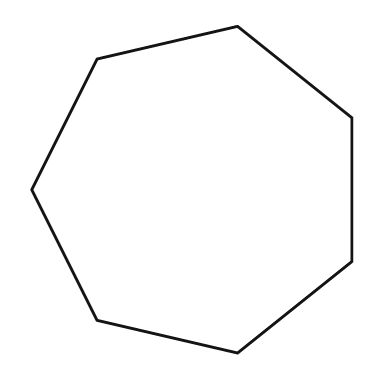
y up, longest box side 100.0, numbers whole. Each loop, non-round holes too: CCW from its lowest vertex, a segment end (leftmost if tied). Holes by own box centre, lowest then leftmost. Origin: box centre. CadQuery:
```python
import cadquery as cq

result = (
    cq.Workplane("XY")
    .moveTo(14.0, -50.0)
    .lineTo(49.0, -22.0)
    .lineTo(49.0, 22.0)
    .lineTo(14.0, 50.0)
    .lineTo(-29.0, 40.0)
    .lineTo(-49.0, 0.0)
    .lineTo(-29.0, -40.0)
    .close()
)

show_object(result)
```